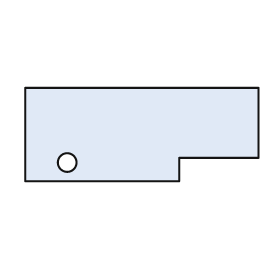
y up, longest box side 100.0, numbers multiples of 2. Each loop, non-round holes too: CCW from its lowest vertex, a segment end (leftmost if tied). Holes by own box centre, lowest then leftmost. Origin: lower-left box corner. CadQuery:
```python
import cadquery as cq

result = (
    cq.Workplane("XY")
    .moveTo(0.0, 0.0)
    .lineTo(66.0, 0.0)
    .lineTo(66.0, 10.0)
    .lineTo(100.0, 10.0)
    .lineTo(100.0, 40.0)
    .lineTo(0.0, 40.0)
    .close()
    .moveTo(18.0, 8.0)
    .circle(4.0)
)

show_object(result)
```